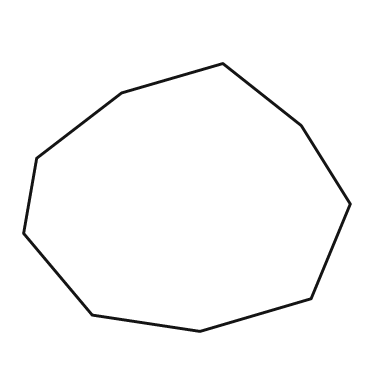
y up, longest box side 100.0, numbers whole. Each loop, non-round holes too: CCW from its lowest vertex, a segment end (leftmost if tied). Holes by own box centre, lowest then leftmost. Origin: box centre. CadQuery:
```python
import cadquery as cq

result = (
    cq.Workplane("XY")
    .moveTo(4.0, -41.0)
    .lineTo(38.0, -31.0)
    .lineTo(50.0, -2.0)
    .lineTo(35.0, 22.0)
    .lineTo(11.0, 41.0)
    .lineTo(-20.0, 32.0)
    .lineTo(-46.0, 12.0)
    .lineTo(-50.0, -11.0)
    .lineTo(-29.0, -36.0)
    .close()
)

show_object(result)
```